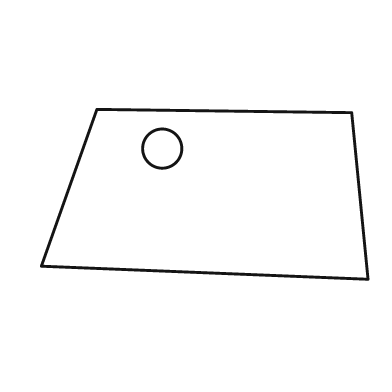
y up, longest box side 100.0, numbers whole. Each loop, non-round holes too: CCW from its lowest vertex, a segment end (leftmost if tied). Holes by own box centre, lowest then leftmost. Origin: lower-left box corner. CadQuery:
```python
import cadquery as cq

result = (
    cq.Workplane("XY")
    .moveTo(100.0, 0.0)
    .lineTo(95.0, 51.0)
    .lineTo(17.0, 52.0)
    .lineTo(0.0, 4.0)
    .close()
    .moveTo(37.0, 40.0)
    .circle(6.0)
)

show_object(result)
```